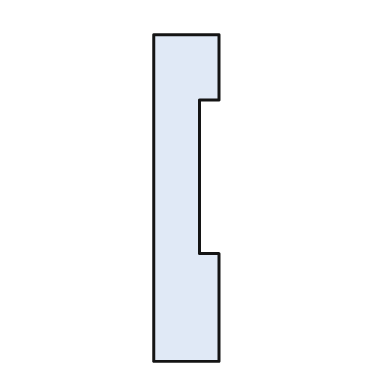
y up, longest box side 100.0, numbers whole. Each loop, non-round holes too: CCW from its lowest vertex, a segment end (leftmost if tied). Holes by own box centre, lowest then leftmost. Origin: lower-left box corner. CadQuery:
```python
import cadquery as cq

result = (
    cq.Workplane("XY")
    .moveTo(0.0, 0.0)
    .lineTo(20.0, 0.0)
    .lineTo(20.0, 33.0)
    .lineTo(14.0, 33.0)
    .lineTo(14.0, 80.0)
    .lineTo(20.0, 80.0)
    .lineTo(20.0, 100.0)
    .lineTo(0.0, 100.0)
    .close()
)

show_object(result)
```